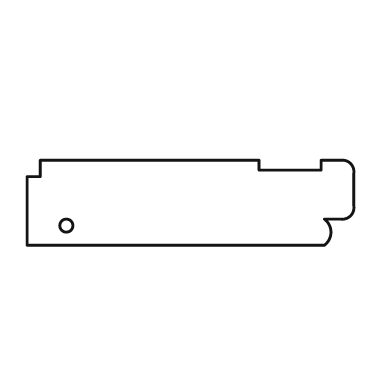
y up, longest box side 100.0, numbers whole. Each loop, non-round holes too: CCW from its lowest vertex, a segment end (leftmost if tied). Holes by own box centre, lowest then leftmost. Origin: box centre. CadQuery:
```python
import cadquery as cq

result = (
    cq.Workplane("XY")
    .moveTo(-50.0, -13.0)
    .lineTo(41.0, -13.0)
    .threePointArc((43.0, -9.0), (41.0, -5.0))
    .lineTo(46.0, -5.0)
    .threePointArc((49.0, -4.0), (50.0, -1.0))
    .lineTo(50.0, 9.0)
    .threePointArc((49.0, 12.0), (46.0, 13.0))
    .lineTo(40.0, 13.0)
    .lineTo(40.0, 10.0)
    .lineTo(21.0, 10.0)
    .lineTo(21.0, 13.0)
    .lineTo(-46.0, 13.0)
    .lineTo(-46.0, 8.0)
    .lineTo(-50.0, 8.0)
    .close()
    .moveTo(-38.0, -7.0)
    .circle(2.0)
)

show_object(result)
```